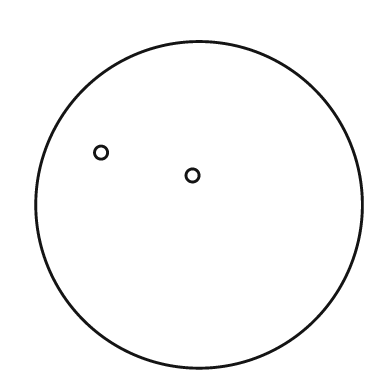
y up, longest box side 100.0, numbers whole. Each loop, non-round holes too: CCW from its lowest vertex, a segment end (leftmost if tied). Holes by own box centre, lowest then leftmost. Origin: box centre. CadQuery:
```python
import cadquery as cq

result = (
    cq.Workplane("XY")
    .moveTo(0.0, 0.0)
    .circle(50.0)
    .moveTo(-2.0, 9.0)
    .circle(2.0)
    .moveTo(-30.0, 16.0)
    .circle(2.0)
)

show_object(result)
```